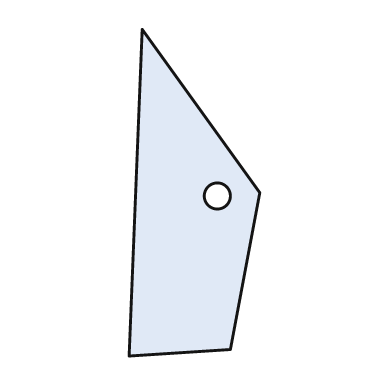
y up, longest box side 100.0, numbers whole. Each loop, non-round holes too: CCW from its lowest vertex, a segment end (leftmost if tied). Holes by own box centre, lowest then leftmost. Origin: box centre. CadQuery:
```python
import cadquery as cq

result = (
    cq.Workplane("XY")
    .moveTo(-20.0, -50.0)
    .lineTo(11.0, -48.0)
    .lineTo(20.0, 0.0)
    .lineTo(-16.0, 50.0)
    .close()
    .moveTo(7.0, -1.0)
    .circle(4.0)
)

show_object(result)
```